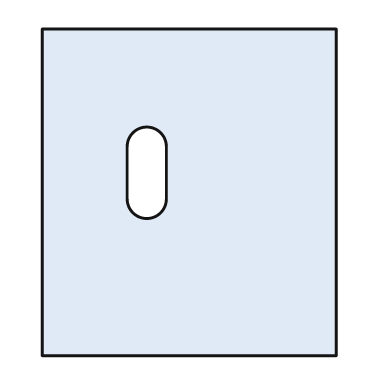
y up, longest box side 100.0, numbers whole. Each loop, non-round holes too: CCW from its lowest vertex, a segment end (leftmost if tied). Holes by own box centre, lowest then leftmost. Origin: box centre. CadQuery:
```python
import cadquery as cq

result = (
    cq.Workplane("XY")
    .moveTo(-45.0, -50.0)
    .lineTo(45.0, -50.0)
    .lineTo(45.0, 50.0)
    .lineTo(-45.0, 50.0)
    .close()
    .moveTo(-19.0, -2.0)
    .threePointArc((-13.0, -8.0), (-7.0, -2.0))
    .lineTo(-7.0, 14.0)
    .threePointArc((-13.0, 20.0), (-19.0, 14.0))
    .close()
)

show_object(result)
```